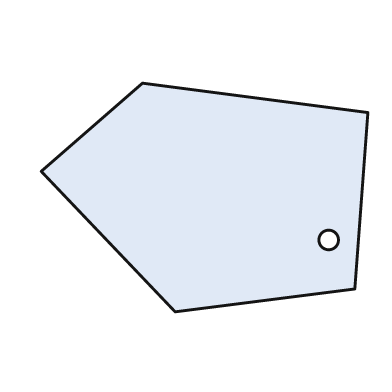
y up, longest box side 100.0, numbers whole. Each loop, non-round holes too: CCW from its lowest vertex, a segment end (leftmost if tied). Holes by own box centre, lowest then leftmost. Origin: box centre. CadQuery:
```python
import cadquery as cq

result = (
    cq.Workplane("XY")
    .moveTo(-9.0, -35.0)
    .lineTo(46.0, -28.0)
    .lineTo(50.0, 26.0)
    .lineTo(-19.0, 35.0)
    .lineTo(-50.0, 8.0)
    .close()
    .moveTo(38.0, -13.0)
    .circle(3.0)
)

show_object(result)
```